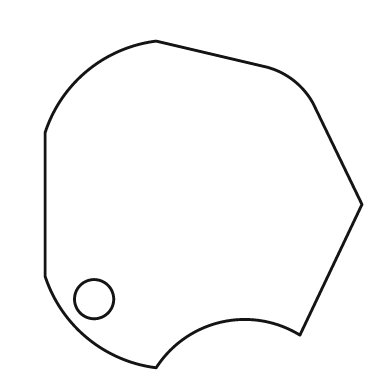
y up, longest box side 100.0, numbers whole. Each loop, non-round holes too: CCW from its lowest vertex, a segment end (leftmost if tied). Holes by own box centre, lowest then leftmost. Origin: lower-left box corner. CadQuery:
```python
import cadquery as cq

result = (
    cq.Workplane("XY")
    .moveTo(34.0, 0.0)
    .threePointArc((54.0, 14.0), (78.0, 10.0))
    .lineTo(97.0, 50.0)
    .lineTo(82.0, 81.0)
    .threePointArc((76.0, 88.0), (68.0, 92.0))
    .lineTo(34.0, 100.0)
    .threePointArc((13.0, 91.0), (0.0, 72.0))
    .lineTo(0.0, 28.0)
    .threePointArc((13.0, 9.0), (34.0, 0.0))
    .close()
    .moveTo(15.0, 21.0)
    .circle(6.0)
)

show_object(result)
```